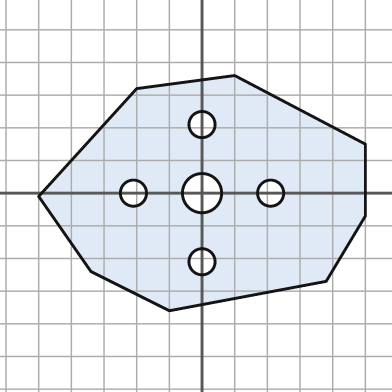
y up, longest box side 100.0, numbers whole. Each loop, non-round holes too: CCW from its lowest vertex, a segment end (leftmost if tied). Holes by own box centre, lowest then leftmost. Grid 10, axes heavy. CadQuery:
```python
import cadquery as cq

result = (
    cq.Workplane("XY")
    .moveTo(-10.0, -36.0)
    .lineTo(38.0, -27.0)
    .lineTo(50.0, -7.0)
    .lineTo(50.0, 15.0)
    .lineTo(10.0, 36.0)
    .lineTo(-20.0, 32.0)
    .lineTo(-50.0, -1.0)
    .lineTo(-34.0, -24.0)
    .close()
    .moveTo(0.0, -21.0)
    .circle(4.0)
    .moveTo(-21.0, 0.0)
    .circle(4.0)
    .moveTo(0.0, 0.0)
    .circle(6.0)
    .moveTo(21.0, 0.0)
    .circle(4.0)
    .moveTo(0.0, 21.0)
    .circle(4.0)
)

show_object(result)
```